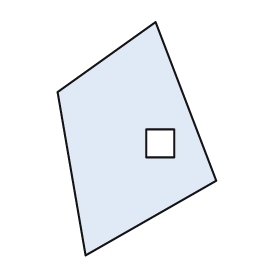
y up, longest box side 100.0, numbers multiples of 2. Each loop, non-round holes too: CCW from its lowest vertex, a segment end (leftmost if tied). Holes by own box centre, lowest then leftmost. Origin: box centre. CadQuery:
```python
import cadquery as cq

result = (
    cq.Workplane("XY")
    .moveTo(-22.0, -50.0)
    .lineTo(34.0, -18.0)
    .lineTo(8.0, 50.0)
    .lineTo(-34.0, 20.0)
    .close()
    .moveTo(4.0, -8.0)
    .lineTo(16.0, -8.0)
    .lineTo(16.0, 4.0)
    .lineTo(4.0, 4.0)
    .close()
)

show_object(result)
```